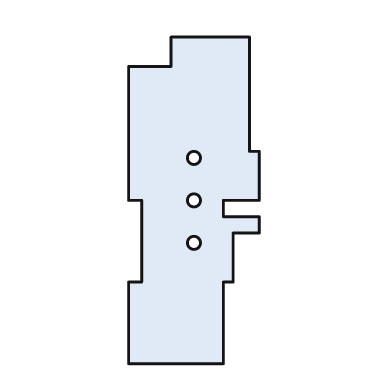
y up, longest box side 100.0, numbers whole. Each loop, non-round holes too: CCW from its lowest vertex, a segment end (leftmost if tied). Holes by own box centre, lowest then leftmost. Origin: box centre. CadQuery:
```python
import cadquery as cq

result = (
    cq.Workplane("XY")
    .moveTo(-20.0, -50.0)
    .lineTo(9.0, -50.0)
    .lineTo(9.0, -25.0)
    .lineTo(12.0, -25.0)
    .lineTo(12.0, -10.0)
    .lineTo(20.0, -10.0)
    .lineTo(20.0, -5.0)
    .lineTo(9.0, -5.0)
    .lineTo(9.0, 0.0)
    .lineTo(20.0, 0.0)
    .lineTo(20.0, 15.0)
    .lineTo(17.0, 15.0)
    .lineTo(17.0, 50.0)
    .lineTo(-7.0, 50.0)
    .lineTo(-7.0, 41.0)
    .lineTo(-20.0, 41.0)
    .lineTo(-20.0, 0.0)
    .lineTo(-16.0, 0.0)
    .lineTo(-16.0, -25.0)
    .lineTo(-20.0, -25.0)
    .close()
    .moveTo(0.0, -13.0)
    .circle(2.0)
    .moveTo(0.0, 0.0)
    .circle(2.0)
    .moveTo(0.0, 13.0)
    .circle(2.0)
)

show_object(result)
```